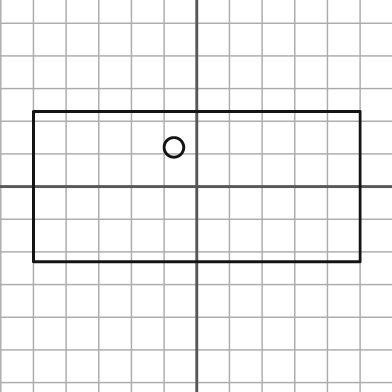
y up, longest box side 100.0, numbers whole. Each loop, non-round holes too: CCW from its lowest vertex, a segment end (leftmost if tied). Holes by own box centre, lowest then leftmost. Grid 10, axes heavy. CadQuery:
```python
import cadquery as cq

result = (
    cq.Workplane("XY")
    .moveTo(-50.0, -23.0)
    .lineTo(50.0, -23.0)
    .lineTo(50.0, 23.0)
    .lineTo(-50.0, 23.0)
    .close()
    .moveTo(-7.0, 12.0)
    .circle(3.0)
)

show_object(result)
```